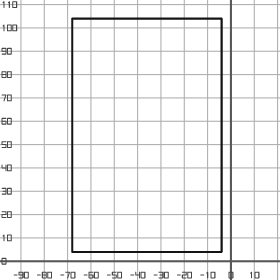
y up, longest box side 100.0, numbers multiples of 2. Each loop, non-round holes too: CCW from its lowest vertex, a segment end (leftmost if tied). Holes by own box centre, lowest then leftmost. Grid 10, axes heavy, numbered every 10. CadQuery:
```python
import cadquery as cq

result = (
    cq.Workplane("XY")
    .moveTo(-68.0, 4.0)
    .lineTo(-4.0, 4.0)
    .lineTo(-4.0, 104.0)
    .lineTo(-68.0, 104.0)
    .close()
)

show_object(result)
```